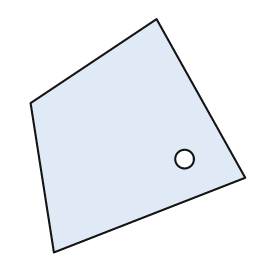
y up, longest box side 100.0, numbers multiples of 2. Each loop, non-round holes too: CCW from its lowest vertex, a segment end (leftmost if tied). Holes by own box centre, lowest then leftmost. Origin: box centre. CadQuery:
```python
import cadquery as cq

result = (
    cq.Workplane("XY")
    .moveTo(-36.0, -50.0)
    .lineTo(46.0, -18.0)
    .lineTo(8.0, 50.0)
    .lineTo(-46.0, 14.0)
    .close()
    .moveTo(20.0, -10.0)
    .circle(4.0)
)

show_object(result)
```